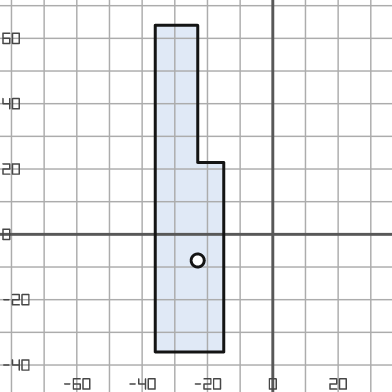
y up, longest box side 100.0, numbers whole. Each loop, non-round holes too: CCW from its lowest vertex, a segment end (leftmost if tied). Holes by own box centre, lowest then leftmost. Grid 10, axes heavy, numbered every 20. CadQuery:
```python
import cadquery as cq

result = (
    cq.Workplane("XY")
    .moveTo(-36.0, -36.0)
    .lineTo(-15.0, -36.0)
    .lineTo(-15.0, 22.0)
    .lineTo(-23.0, 22.0)
    .lineTo(-23.0, 64.0)
    .lineTo(-36.0, 64.0)
    .close()
    .moveTo(-23.0, -8.0)
    .circle(2.0)
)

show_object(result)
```